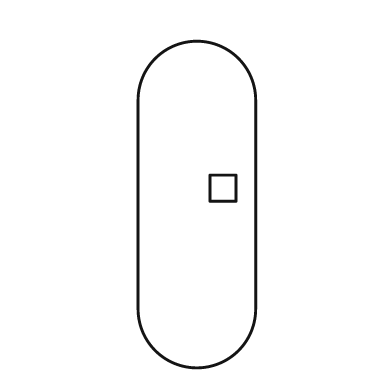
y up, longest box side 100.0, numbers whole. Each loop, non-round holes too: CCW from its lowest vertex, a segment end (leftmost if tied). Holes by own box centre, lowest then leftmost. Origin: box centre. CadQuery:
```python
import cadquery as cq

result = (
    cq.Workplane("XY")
    .moveTo(-18.0, -32.0)
    .threePointArc((0.0, -50.0), (18.0, -32.0))
    .lineTo(18.0, 32.0)
    .threePointArc((0.0, 50.0), (-18.0, 32.0))
    .close()
    .moveTo(4.0, 1.0)
    .lineTo(12.0, 1.0)
    .lineTo(12.0, 9.0)
    .lineTo(4.0, 9.0)
    .close()
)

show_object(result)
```